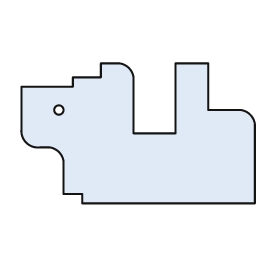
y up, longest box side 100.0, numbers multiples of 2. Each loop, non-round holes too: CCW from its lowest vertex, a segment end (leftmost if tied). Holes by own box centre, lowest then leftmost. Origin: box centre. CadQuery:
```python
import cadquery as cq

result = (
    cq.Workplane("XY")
    .moveTo(-24.0, -30.0)
    .lineTo(50.0, -30.0)
    .lineTo(50.0, 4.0)
    .threePointArc((48.0, 8.0), (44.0, 10.0))
    .lineTo(30.0, 10.0)
    .lineTo(30.0, 30.0)
    .lineTo(16.0, 30.0)
    .lineTo(16.0, 0.0)
    .lineTo(-2.0, 0.0)
    .lineTo(-2.0, 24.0)
    .threePointArc((-4.0, 28.0), (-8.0, 30.0))
    .lineTo(-16.0, 30.0)
    .lineTo(-16.0, 24.0)
    .lineTo(-28.0, 24.0)
    .lineTo(-28.0, 20.0)
    .lineTo(-50.0, 20.0)
    .lineTo(-50.0, 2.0)
    .threePointArc((-48.0, -4.0), (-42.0, -6.0))
    .lineTo(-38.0, -6.0)
    .threePointArc((-34.0, -8.0), (-32.0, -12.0))
    .lineTo(-32.0, -26.0)
    .lineTo(-24.0, -26.0)
    .close()
    .moveTo(-34.0, 10.0)
    .circle(2.0)
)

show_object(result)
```